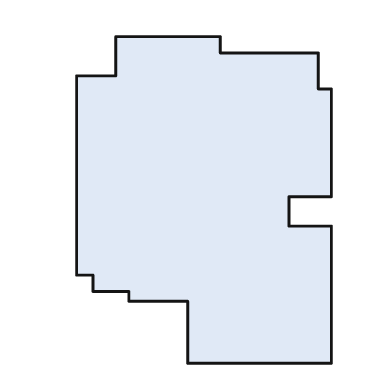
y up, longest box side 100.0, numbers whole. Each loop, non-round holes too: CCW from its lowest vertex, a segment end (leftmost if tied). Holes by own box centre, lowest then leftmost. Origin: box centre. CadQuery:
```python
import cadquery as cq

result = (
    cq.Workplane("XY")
    .moveTo(-5.0, -50.0)
    .lineTo(39.0, -50.0)
    .lineTo(39.0, -8.0)
    .lineTo(26.0, -8.0)
    .lineTo(26.0, 1.0)
    .lineTo(39.0, 1.0)
    .lineTo(39.0, 34.0)
    .lineTo(35.0, 34.0)
    .lineTo(35.0, 45.0)
    .lineTo(5.0, 45.0)
    .lineTo(5.0, 50.0)
    .lineTo(-27.0, 50.0)
    .lineTo(-27.0, 38.0)
    .lineTo(-39.0, 38.0)
    .lineTo(-39.0, -23.0)
    .lineTo(-34.0, -23.0)
    .lineTo(-34.0, -28.0)
    .lineTo(-23.0, -28.0)
    .lineTo(-23.0, -31.0)
    .lineTo(-5.0, -31.0)
    .close()
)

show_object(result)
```